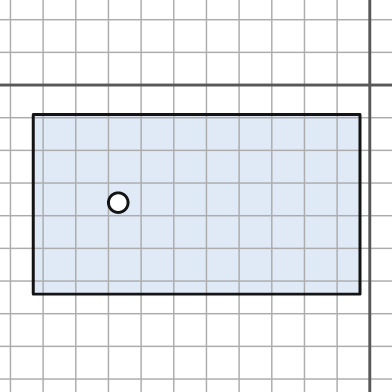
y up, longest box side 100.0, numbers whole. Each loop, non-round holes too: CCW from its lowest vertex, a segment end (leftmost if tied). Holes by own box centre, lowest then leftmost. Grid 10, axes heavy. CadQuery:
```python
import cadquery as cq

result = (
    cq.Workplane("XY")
    .moveTo(-103.0, -64.0)
    .lineTo(-3.0, -64.0)
    .lineTo(-3.0, -9.0)
    .lineTo(-103.0, -9.0)
    .close()
    .moveTo(-77.0, -36.0)
    .circle(3.0)
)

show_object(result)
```